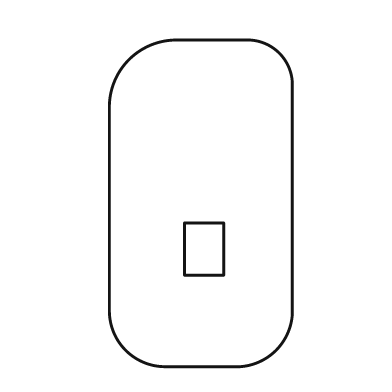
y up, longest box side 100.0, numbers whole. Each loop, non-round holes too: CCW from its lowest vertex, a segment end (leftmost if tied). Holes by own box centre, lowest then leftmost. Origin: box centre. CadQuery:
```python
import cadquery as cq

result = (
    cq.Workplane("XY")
    .moveTo(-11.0, -50.0)
    .lineTo(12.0, -50.0)
    .threePointArc((23.0, -45.0), (28.0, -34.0))
    .lineTo(28.0, 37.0)
    .threePointArc((24.0, 46.0), (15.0, 50.0))
    .lineTo(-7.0, 50.0)
    .threePointArc((-22.0, 44.0), (-28.0, 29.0))
    .lineTo(-28.0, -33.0)
    .threePointArc((-23.0, -45.0), (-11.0, -50.0))
    .close()
    .moveTo(-5.0, -22.0)
    .lineTo(7.0, -22.0)
    .lineTo(7.0, -6.0)
    .lineTo(-5.0, -6.0)
    .close()
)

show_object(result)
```